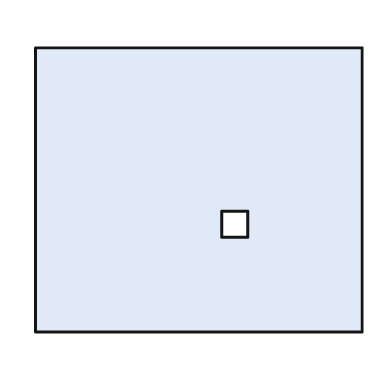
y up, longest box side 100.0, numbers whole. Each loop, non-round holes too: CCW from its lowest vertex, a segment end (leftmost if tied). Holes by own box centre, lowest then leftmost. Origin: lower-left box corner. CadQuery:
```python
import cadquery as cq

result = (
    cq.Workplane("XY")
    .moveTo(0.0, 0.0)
    .lineTo(100.0, 0.0)
    .lineTo(100.0, 87.0)
    .lineTo(0.0, 87.0)
    .close()
    .moveTo(57.0, 29.0)
    .lineTo(65.0, 29.0)
    .lineTo(65.0, 37.0)
    .lineTo(57.0, 37.0)
    .close()
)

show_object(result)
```